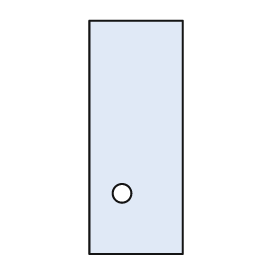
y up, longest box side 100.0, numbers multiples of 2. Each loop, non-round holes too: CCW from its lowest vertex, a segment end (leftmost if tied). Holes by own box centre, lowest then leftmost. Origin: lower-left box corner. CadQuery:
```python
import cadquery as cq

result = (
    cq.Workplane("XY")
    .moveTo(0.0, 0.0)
    .lineTo(40.0, 0.0)
    .lineTo(40.0, 100.0)
    .lineTo(0.0, 100.0)
    .close()
    .moveTo(14.0, 26.0)
    .circle(4.0)
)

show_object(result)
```